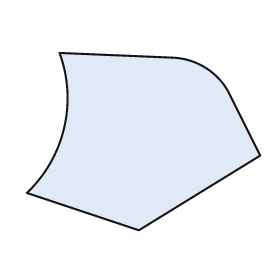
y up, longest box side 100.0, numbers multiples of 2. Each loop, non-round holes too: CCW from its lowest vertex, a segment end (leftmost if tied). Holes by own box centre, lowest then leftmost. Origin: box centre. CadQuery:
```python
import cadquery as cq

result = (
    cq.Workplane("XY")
    .moveTo(-2.0, -38.0)
    .lineTo(50.0, -6.0)
    .lineTo(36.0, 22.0)
    .threePointArc((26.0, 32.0), (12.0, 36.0))
    .lineTo(-36.0, 38.0)
    .threePointArc((-34.0, 6.0), (-50.0, -22.0))
    .close()
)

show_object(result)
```